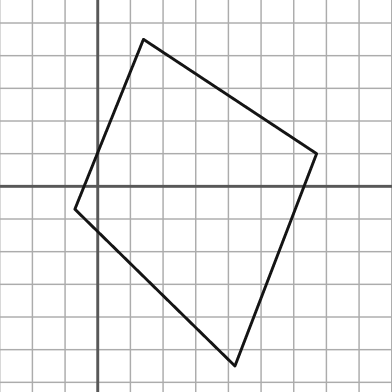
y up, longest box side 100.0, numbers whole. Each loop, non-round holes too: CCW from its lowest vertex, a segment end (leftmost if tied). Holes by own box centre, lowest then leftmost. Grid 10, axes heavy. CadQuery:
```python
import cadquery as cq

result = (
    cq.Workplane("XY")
    .moveTo(42.0, -55.0)
    .lineTo(67.0, 10.0)
    .lineTo(14.0, 45.0)
    .lineTo(-7.0, -7.0)
    .close()
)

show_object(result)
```